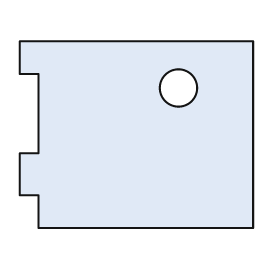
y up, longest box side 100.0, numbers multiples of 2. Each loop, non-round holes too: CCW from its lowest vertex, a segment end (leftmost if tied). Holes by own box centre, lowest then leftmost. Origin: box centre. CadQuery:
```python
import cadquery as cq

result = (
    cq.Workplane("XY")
    .moveTo(-42.0, -40.0)
    .lineTo(50.0, -40.0)
    .lineTo(50.0, 40.0)
    .lineTo(-50.0, 40.0)
    .lineTo(-50.0, 26.0)
    .lineTo(-42.0, 26.0)
    .lineTo(-42.0, -8.0)
    .lineTo(-50.0, -8.0)
    .lineTo(-50.0, -26.0)
    .lineTo(-42.0, -26.0)
    .close()
    .moveTo(18.0, 20.0)
    .circle(8.0)
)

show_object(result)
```